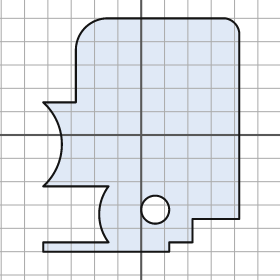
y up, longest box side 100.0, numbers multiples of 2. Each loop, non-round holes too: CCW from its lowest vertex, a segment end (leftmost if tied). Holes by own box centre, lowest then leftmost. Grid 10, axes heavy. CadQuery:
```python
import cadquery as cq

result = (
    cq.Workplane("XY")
    .moveTo(-42.0, -50.0)
    .lineTo(12.0, -50.0)
    .lineTo(12.0, -46.0)
    .lineTo(22.0, -46.0)
    .lineTo(22.0, -36.0)
    .lineTo(42.0, -36.0)
    .lineTo(42.0, 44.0)
    .threePointArc((40.0, 48.0), (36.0, 50.0))
    .lineTo(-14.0, 50.0)
    .threePointArc((-24.0, 46.0), (-28.0, 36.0))
    .lineTo(-28.0, 14.0)
    .lineTo(-42.0, 14.0)
    .threePointArc((-34.0, -4.0), (-42.0, -22.0))
    .lineTo(-14.0, -22.0)
    .threePointArc((-18.0, -34.0), (-14.0, -46.0))
    .lineTo(-42.0, -46.0)
    .close()
    .moveTo(6.0, -32.0)
    .circle(6.0)
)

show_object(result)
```